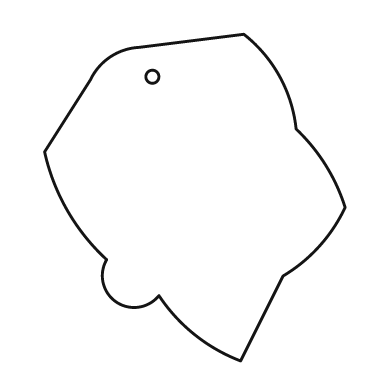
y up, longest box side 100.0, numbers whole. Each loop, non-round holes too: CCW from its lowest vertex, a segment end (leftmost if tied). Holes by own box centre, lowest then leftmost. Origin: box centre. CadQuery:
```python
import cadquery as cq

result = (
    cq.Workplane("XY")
    .moveTo(14.0, -50.0)
    .lineTo(27.0, -24.0)
    .threePointArc((38.0, -15.0), (46.0, -3.0))
    .threePointArc((40.0, 10.0), (31.0, 21.0))
    .threePointArc((26.0, 37.0), (15.0, 50.0))
    .lineTo(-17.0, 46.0)
    .threePointArc((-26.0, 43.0), (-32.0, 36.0))
    .lineTo(-46.0, 14.0)
    .threePointArc((-39.0, -4.0), (-27.0, -19.0))
    .threePointArc((-24.0, -32.0), (-11.0, -30.0))
    .threePointArc((0.0, -42.0), (14.0, -50.0))
    .close()
    .moveTo(-13.0, 37.0)
    .circle(2.0)
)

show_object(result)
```